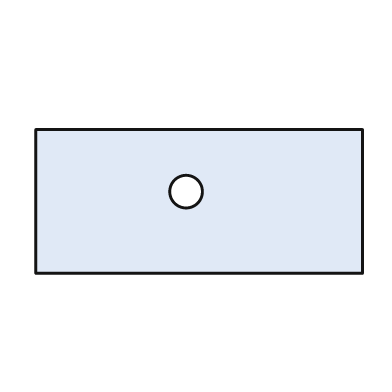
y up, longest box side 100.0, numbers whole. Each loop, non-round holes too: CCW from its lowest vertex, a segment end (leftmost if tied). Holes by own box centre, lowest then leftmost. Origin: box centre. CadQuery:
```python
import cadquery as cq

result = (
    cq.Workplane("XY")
    .moveTo(-50.0, -22.0)
    .lineTo(50.0, -22.0)
    .lineTo(50.0, 22.0)
    .lineTo(-50.0, 22.0)
    .close()
    .moveTo(-4.0, 3.0)
    .circle(5.0)
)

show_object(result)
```